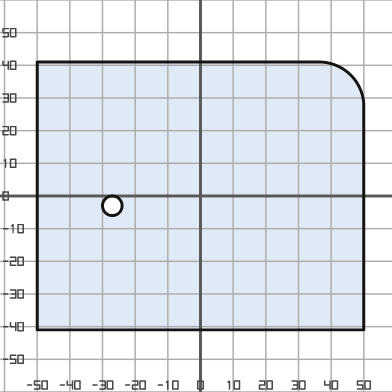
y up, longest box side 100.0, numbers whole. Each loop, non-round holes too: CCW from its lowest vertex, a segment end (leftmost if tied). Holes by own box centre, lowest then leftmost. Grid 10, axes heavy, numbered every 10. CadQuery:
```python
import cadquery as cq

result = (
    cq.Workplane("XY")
    .moveTo(-50.0, -41.0)
    .lineTo(50.0, -41.0)
    .lineTo(50.0, 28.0)
    .threePointArc((46.0, 37.0), (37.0, 41.0))
    .lineTo(-50.0, 41.0)
    .close()
    .moveTo(-27.0, -3.0)
    .circle(3.0)
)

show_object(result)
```